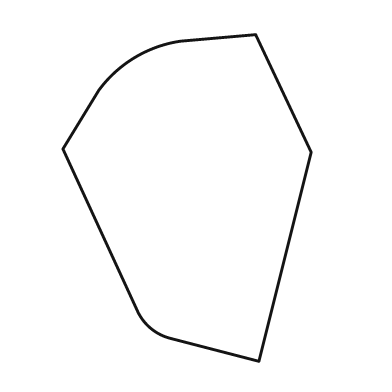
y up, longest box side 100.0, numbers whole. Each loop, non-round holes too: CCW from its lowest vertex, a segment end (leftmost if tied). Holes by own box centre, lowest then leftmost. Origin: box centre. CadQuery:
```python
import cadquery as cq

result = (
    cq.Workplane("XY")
    .moveTo(22.0, -50.0)
    .lineTo(38.0, 14.0)
    .lineTo(21.0, 50.0)
    .lineTo(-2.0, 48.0)
    .threePointArc((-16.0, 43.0), (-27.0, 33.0))
    .lineTo(-38.0, 15.0)
    .lineTo(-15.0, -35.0)
    .threePointArc((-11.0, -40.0), (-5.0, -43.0))
    .close()
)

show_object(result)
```